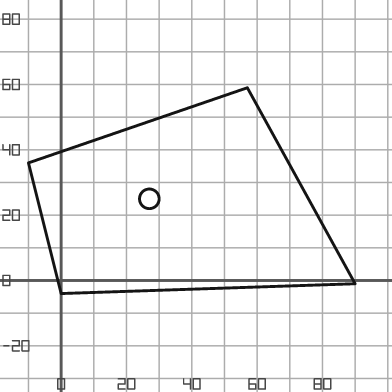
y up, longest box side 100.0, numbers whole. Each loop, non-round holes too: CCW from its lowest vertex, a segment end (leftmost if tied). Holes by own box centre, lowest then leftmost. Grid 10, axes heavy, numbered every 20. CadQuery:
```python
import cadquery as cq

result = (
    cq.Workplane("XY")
    .moveTo(0.0, -4.0)
    .lineTo(90.0, -1.0)
    .lineTo(57.0, 59.0)
    .lineTo(-10.0, 36.0)
    .close()
    .moveTo(27.0, 25.0)
    .circle(3.0)
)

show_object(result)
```